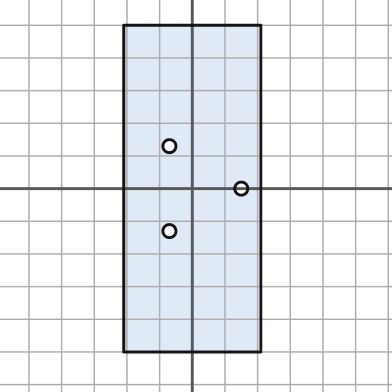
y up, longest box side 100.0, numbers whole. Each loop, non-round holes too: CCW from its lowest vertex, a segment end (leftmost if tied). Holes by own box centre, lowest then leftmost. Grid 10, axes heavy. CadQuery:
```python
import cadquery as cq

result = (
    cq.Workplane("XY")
    .moveTo(-21.0, -50.0)
    .lineTo(21.0, -50.0)
    .lineTo(21.0, 50.0)
    .lineTo(-21.0, 50.0)
    .close()
    .moveTo(-7.0, -13.0)
    .circle(2.0)
    .moveTo(15.0, 0.0)
    .circle(2.0)
    .moveTo(-7.0, 13.0)
    .circle(2.0)
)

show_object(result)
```